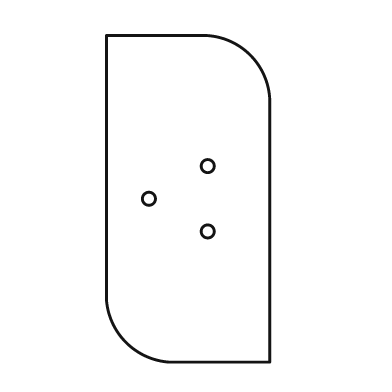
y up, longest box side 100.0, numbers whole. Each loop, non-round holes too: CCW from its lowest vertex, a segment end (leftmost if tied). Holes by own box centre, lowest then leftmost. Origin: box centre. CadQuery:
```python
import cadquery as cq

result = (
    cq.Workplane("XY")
    .moveTo(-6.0, -50.0)
    .lineTo(25.0, -50.0)
    .lineTo(25.0, 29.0)
    .threePointArc((19.0, 44.0), (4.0, 50.0))
    .lineTo(-25.0, 50.0)
    .lineTo(-25.0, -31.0)
    .threePointArc((-19.0, -44.0), (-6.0, -50.0))
    .close()
    .moveTo(6.0, -10.0)
    .circle(2.0)
    .moveTo(-12.0, 0.0)
    .circle(2.0)
    .moveTo(6.0, 10.0)
    .circle(2.0)
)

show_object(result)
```